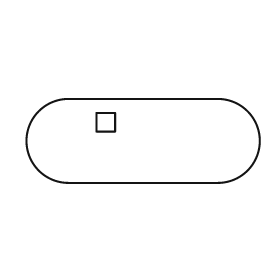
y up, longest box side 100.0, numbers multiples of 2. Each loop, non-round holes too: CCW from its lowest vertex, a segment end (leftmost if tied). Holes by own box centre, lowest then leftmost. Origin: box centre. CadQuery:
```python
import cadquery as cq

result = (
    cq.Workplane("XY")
    .moveTo(-32.0, -18.0)
    .lineTo(32.0, -18.0)
    .threePointArc((50.0, 0.0), (32.0, 18.0))
    .lineTo(-32.0, 18.0)
    .threePointArc((-50.0, 0.0), (-32.0, -18.0))
    .close()
    .moveTo(-20.0, 4.0)
    .lineTo(-12.0, 4.0)
    .lineTo(-12.0, 12.0)
    .lineTo(-20.0, 12.0)
    .close()
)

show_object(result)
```